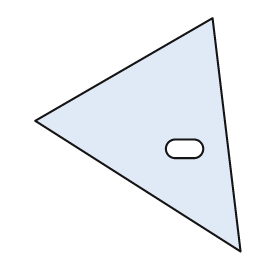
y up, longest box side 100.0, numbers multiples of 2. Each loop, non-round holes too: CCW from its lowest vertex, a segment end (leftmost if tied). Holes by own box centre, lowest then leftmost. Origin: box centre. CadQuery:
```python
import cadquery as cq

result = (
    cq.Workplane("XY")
    .moveTo(44.0, -50.0)
    .lineTo(32.0, 50.0)
    .lineTo(-44.0, 6.0)
    .close()
    .moveTo(16.0, -10.0)
    .lineTo(24.0, -10.0)
    .threePointArc((28.0, -6.0), (24.0, -2.0))
    .lineTo(16.0, -2.0)
    .threePointArc((12.0, -6.0), (16.0, -10.0))
    .close()
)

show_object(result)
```